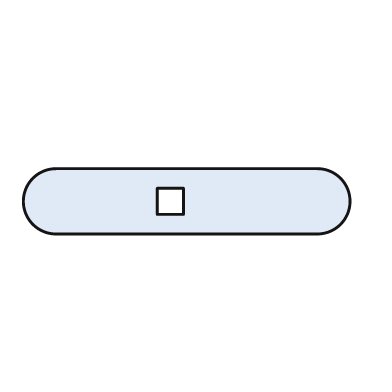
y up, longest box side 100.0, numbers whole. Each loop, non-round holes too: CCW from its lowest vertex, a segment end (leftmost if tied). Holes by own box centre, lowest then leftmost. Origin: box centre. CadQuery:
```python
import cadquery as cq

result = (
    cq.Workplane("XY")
    .moveTo(-40.0, -10.0)
    .lineTo(40.0, -10.0)
    .threePointArc((50.0, 0.0), (40.0, 10.0))
    .lineTo(-40.0, 10.0)
    .threePointArc((-50.0, 0.0), (-40.0, -10.0))
    .close()
    .moveTo(-9.0, -4.0)
    .lineTo(-1.0, -4.0)
    .lineTo(-1.0, 4.0)
    .lineTo(-9.0, 4.0)
    .close()
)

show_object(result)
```